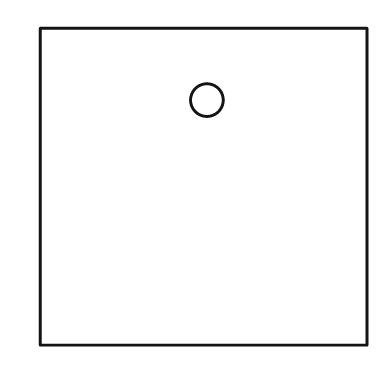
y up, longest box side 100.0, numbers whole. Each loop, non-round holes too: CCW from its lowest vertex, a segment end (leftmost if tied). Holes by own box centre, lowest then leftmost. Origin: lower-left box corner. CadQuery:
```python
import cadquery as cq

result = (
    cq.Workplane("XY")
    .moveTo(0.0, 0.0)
    .lineTo(100.0, 0.0)
    .lineTo(100.0, 97.0)
    .lineTo(0.0, 97.0)
    .close()
    .moveTo(51.0, 75.0)
    .circle(5.0)
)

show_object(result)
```